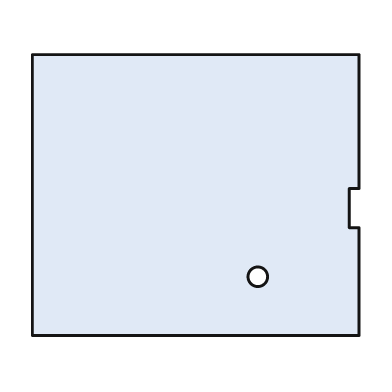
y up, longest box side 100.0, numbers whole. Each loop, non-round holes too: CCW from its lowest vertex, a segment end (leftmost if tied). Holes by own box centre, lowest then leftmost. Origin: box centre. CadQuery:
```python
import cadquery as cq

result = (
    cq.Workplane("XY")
    .moveTo(-50.0, -43.0)
    .lineTo(50.0, -43.0)
    .lineTo(50.0, -10.0)
    .lineTo(47.0, -10.0)
    .lineTo(47.0, 2.0)
    .lineTo(50.0, 2.0)
    .lineTo(50.0, 43.0)
    .lineTo(-50.0, 43.0)
    .close()
    .moveTo(19.0, -25.0)
    .circle(3.0)
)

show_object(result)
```